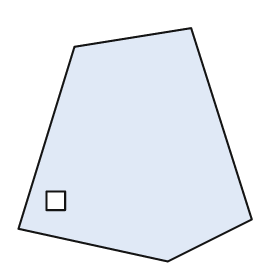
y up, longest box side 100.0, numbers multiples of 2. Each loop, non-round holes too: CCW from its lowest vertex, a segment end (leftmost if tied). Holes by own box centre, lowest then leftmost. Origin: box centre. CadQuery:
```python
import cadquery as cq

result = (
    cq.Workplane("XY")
    .moveTo(14.0, -50.0)
    .lineTo(50.0, -32.0)
    .lineTo(24.0, 50.0)
    .lineTo(-26.0, 42.0)
    .lineTo(-50.0, -36.0)
    .close()
    .moveTo(-38.0, -28.0)
    .lineTo(-30.0, -28.0)
    .lineTo(-30.0, -20.0)
    .lineTo(-38.0, -20.0)
    .close()
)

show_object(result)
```